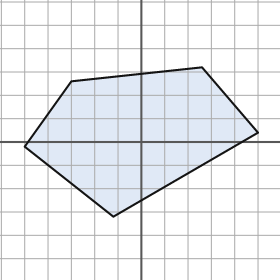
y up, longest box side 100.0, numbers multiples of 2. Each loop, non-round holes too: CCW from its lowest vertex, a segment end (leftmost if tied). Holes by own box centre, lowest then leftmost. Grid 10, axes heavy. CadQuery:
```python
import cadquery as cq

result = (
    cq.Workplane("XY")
    .moveTo(-12.0, -32.0)
    .lineTo(50.0, 4.0)
    .lineTo(26.0, 32.0)
    .lineTo(-30.0, 26.0)
    .lineTo(-50.0, -2.0)
    .close()
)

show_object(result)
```